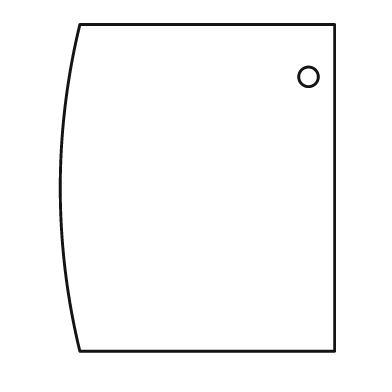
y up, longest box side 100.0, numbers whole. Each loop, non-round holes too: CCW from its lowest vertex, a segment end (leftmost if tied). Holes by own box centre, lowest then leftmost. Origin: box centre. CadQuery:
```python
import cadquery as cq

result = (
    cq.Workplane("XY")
    .moveTo(-36.0, -50.0)
    .lineTo(42.0, -50.0)
    .lineTo(42.0, 50.0)
    .lineTo(-36.0, 50.0)
    .threePointArc((-42.0, 0.0), (-36.0, -50.0))
    .close()
    .moveTo(34.0, 34.0)
    .circle(3.0)
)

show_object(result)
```